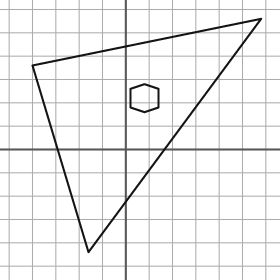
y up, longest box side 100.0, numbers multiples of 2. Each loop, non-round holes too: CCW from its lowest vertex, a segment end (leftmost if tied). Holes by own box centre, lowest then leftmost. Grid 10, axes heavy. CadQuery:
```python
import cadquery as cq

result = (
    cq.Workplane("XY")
    .moveTo(-16.0, -44.0)
    .lineTo(58.0, 56.0)
    .lineTo(-40.0, 36.0)
    .close()
    .moveTo(8.0, 16.0)
    .lineTo(14.0, 18.0)
    .lineTo(14.0, 26.0)
    .lineTo(8.0, 28.0)
    .lineTo(2.0, 26.0)
    .lineTo(2.0, 18.0)
    .close()
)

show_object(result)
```